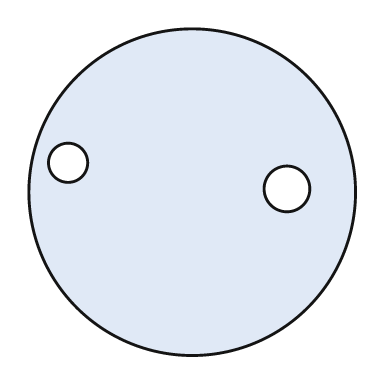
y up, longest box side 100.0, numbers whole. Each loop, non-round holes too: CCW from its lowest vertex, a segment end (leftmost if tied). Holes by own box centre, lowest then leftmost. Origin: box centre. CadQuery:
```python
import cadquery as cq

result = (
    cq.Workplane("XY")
    .moveTo(0.0, 0.0)
    .circle(50.0)
    .moveTo(29.0, 1.0)
    .circle(7.0)
    .moveTo(-38.0, 9.0)
    .circle(6.0)
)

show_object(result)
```